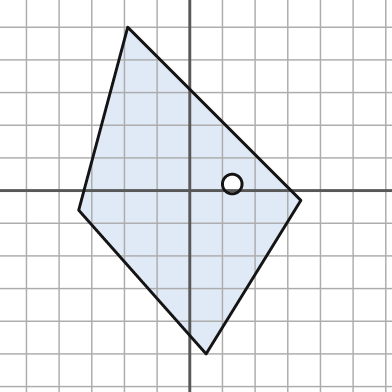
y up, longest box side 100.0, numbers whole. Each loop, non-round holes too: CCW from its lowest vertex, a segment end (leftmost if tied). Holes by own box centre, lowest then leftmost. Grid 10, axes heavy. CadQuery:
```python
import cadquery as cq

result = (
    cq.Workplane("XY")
    .moveTo(5.0, -50.0)
    .lineTo(34.0, -3.0)
    .lineTo(-19.0, 50.0)
    .lineTo(-34.0, -6.0)
    .close()
    .moveTo(13.0, 2.0)
    .circle(3.0)
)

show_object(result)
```